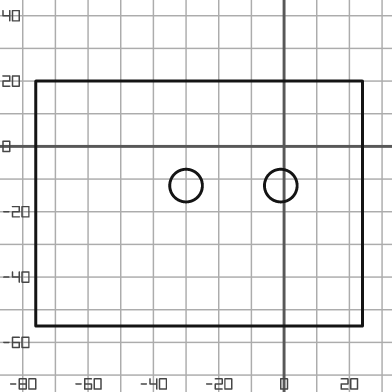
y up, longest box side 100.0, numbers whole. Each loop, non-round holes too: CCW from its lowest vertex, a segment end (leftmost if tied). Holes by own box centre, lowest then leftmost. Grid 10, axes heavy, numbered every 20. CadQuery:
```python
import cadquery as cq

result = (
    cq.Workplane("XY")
    .moveTo(-76.0, -55.0)
    .lineTo(24.0, -55.0)
    .lineTo(24.0, 20.0)
    .lineTo(-76.0, 20.0)
    .close()
    .moveTo(-30.0, -12.0)
    .circle(5.0)
    .moveTo(-1.0, -12.0)
    .circle(5.0)
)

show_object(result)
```